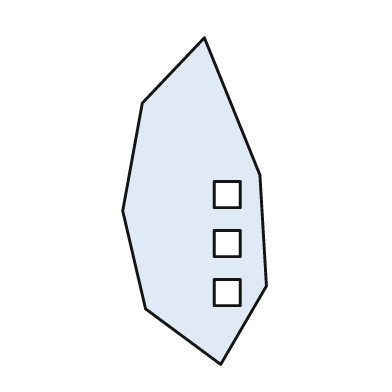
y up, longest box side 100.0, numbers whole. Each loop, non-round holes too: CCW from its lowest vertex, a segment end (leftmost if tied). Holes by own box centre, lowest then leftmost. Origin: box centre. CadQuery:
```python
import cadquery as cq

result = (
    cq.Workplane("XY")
    .moveTo(8.0, -50.0)
    .lineTo(22.0, -26.0)
    .lineTo(20.0, 8.0)
    .lineTo(3.0, 50.0)
    .lineTo(-16.0, 30.0)
    .lineTo(-22.0, -3.0)
    .lineTo(-15.0, -33.0)
    .close()
    .moveTo(6.0, -32.0)
    .lineTo(14.0, -32.0)
    .lineTo(14.0, -24.0)
    .lineTo(6.0, -24.0)
    .close()
    .moveTo(6.0, -17.0)
    .lineTo(14.0, -17.0)
    .lineTo(14.0, -9.0)
    .lineTo(6.0, -9.0)
    .close()
    .moveTo(6.0, -2.0)
    .lineTo(14.0, -2.0)
    .lineTo(14.0, 6.0)
    .lineTo(6.0, 6.0)
    .close()
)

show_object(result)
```